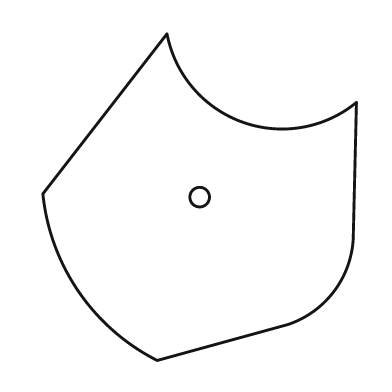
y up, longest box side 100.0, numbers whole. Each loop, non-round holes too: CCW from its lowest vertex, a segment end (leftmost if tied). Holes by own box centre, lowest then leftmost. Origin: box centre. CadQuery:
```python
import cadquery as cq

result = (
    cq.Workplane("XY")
    .moveTo(-13.0, -50.0)
    .lineTo(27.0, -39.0)
    .threePointArc((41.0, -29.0), (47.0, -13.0))
    .lineTo(48.0, 29.0)
    .threePointArc((13.0, 23.0), (-10.0, 50.0))
    .lineTo(-48.0, 1.0)
    .threePointArc((-37.0, -29.0), (-13.0, -50.0))
    .close()
    .moveTo(0.0, 0.0)
    .circle(3.0)
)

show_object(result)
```